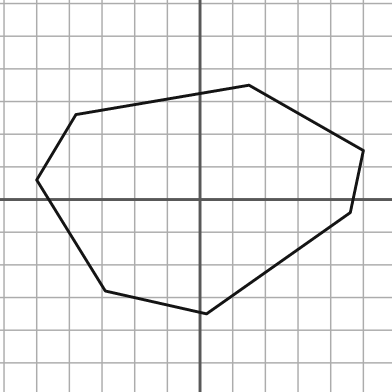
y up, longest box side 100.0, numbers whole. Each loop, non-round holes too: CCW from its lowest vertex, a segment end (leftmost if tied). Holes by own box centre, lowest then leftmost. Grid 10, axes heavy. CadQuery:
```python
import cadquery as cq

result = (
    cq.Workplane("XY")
    .moveTo(2.0, -35.0)
    .lineTo(46.0, -4.0)
    .lineTo(50.0, 15.0)
    .lineTo(15.0, 35.0)
    .lineTo(-38.0, 26.0)
    .lineTo(-50.0, 6.0)
    .lineTo(-29.0, -28.0)
    .close()
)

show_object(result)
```